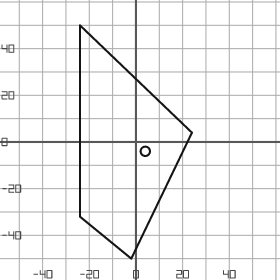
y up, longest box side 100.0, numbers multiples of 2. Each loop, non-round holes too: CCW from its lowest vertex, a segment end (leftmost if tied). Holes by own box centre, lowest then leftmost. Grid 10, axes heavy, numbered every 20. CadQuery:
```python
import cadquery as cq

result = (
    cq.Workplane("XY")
    .moveTo(-2.0, -50.0)
    .lineTo(24.0, 4.0)
    .lineTo(-24.0, 50.0)
    .lineTo(-24.0, -32.0)
    .close()
    .moveTo(4.0, -4.0)
    .circle(2.0)
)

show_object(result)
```